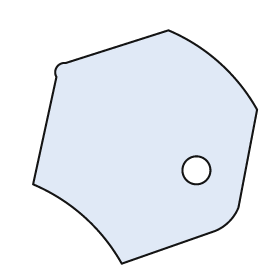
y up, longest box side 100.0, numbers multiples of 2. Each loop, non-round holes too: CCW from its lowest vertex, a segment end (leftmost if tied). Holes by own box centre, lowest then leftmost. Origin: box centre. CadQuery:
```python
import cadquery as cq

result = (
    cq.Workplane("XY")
    .moveTo(-10.0, -50.0)
    .lineTo(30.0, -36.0)
    .threePointArc((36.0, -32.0), (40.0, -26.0))
    .lineTo(48.0, 16.0)
    .threePointArc((32.0, 36.0), (10.0, 50.0))
    .lineTo(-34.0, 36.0)
    .threePointArc((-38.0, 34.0), (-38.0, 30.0))
    .lineTo(-48.0, -16.0)
    .threePointArc((-26.0, -30.0), (-10.0, -50.0))
    .close()
    .moveTo(22.0, -10.0)
    .circle(6.0)
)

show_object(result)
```